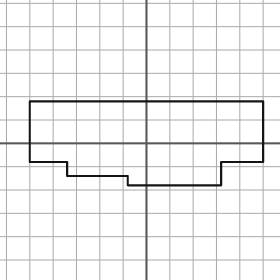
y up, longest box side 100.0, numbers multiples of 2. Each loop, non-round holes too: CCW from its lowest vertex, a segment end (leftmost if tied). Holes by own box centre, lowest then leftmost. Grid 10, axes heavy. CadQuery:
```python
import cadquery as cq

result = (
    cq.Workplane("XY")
    .moveTo(-8.0, -18.0)
    .lineTo(32.0, -18.0)
    .lineTo(32.0, -8.0)
    .lineTo(50.0, -8.0)
    .lineTo(50.0, 18.0)
    .lineTo(-50.0, 18.0)
    .lineTo(-50.0, -8.0)
    .lineTo(-34.0, -8.0)
    .lineTo(-34.0, -14.0)
    .lineTo(-8.0, -14.0)
    .close()
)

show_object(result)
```